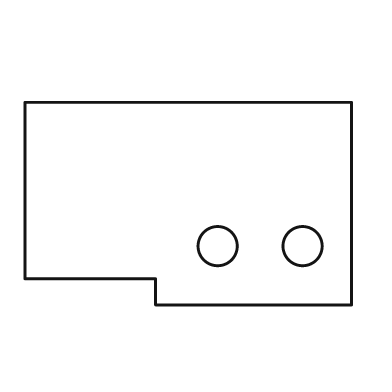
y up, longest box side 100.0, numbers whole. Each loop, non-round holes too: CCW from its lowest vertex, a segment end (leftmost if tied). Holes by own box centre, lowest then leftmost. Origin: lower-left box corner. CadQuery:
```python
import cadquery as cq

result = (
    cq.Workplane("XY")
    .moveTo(40.0, 0.0)
    .lineTo(100.0, 0.0)
    .lineTo(100.0, 62.0)
    .lineTo(0.0, 62.0)
    .lineTo(0.0, 8.0)
    .lineTo(40.0, 8.0)
    .close()
    .moveTo(59.0, 18.0)
    .circle(6.0)
    .moveTo(85.0, 18.0)
    .circle(6.0)
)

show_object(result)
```